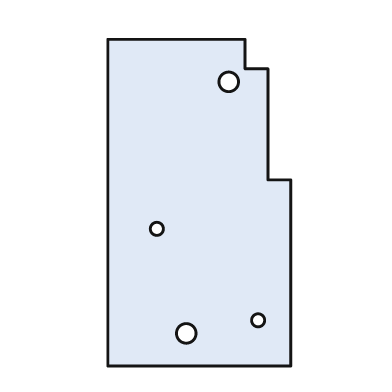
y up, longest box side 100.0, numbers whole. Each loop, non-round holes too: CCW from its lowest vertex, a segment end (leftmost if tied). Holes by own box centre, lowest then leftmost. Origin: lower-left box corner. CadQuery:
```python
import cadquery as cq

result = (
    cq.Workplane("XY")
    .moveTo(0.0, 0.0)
    .lineTo(56.0, 0.0)
    .lineTo(56.0, 57.0)
    .lineTo(49.0, 57.0)
    .lineTo(49.0, 91.0)
    .lineTo(42.0, 91.0)
    .lineTo(42.0, 100.0)
    .lineTo(0.0, 100.0)
    .close()
    .moveTo(24.0, 10.0)
    .circle(3.0)
    .moveTo(46.0, 14.0)
    .circle(2.0)
    .moveTo(15.0, 42.0)
    .circle(2.0)
    .moveTo(37.0, 87.0)
    .circle(3.0)
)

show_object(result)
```